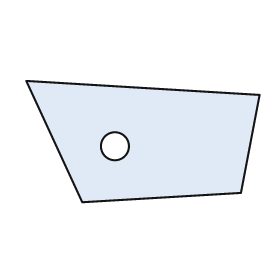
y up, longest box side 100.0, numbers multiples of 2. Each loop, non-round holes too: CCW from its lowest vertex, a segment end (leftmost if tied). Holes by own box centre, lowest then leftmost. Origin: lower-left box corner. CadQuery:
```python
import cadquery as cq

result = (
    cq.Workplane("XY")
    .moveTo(24.0, 0.0)
    .lineTo(92.0, 4.0)
    .lineTo(100.0, 46.0)
    .lineTo(0.0, 52.0)
    .close()
    .moveTo(38.0, 24.0)
    .circle(6.0)
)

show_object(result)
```